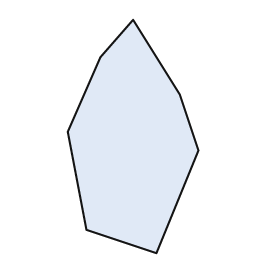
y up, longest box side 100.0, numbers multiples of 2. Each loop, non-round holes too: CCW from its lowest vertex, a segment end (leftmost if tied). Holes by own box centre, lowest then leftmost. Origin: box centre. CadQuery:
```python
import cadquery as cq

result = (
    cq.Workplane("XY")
    .moveTo(10.0, -50.0)
    .lineTo(28.0, -6.0)
    .lineTo(20.0, 18.0)
    .lineTo(0.0, 50.0)
    .lineTo(-14.0, 34.0)
    .lineTo(-28.0, 2.0)
    .lineTo(-20.0, -40.0)
    .close()
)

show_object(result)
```